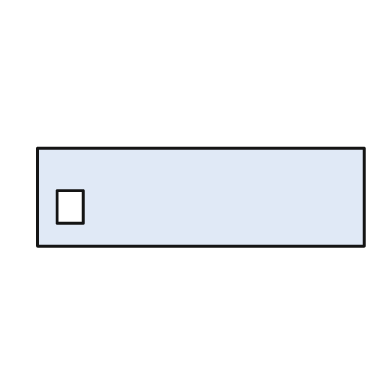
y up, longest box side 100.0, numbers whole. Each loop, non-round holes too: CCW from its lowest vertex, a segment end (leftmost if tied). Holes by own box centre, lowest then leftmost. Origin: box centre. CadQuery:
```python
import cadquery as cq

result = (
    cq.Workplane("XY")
    .moveTo(-50.0, -15.0)
    .lineTo(50.0, -15.0)
    .lineTo(50.0, 15.0)
    .lineTo(-50.0, 15.0)
    .close()
    .moveTo(-44.0, -8.0)
    .lineTo(-36.0, -8.0)
    .lineTo(-36.0, 2.0)
    .lineTo(-44.0, 2.0)
    .close()
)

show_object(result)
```